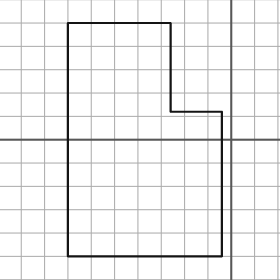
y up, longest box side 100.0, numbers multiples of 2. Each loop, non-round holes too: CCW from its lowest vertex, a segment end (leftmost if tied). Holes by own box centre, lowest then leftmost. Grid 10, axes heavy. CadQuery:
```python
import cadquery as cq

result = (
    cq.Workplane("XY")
    .moveTo(-70.0, -50.0)
    .lineTo(-4.0, -50.0)
    .lineTo(-4.0, 12.0)
    .lineTo(-26.0, 12.0)
    .lineTo(-26.0, 50.0)
    .lineTo(-70.0, 50.0)
    .close()
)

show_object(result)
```